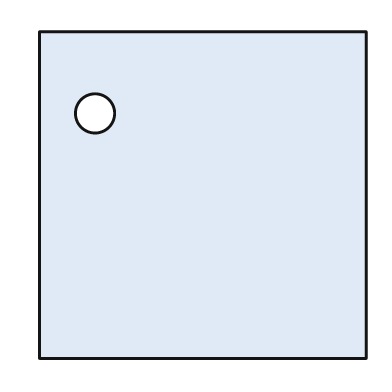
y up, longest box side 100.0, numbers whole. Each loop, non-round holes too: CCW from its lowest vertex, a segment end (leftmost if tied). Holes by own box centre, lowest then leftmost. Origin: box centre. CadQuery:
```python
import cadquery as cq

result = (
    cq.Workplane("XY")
    .moveTo(-50.0, -50.0)
    .lineTo(50.0, -50.0)
    .lineTo(50.0, 50.0)
    .lineTo(-50.0, 50.0)
    .close()
    .moveTo(-33.0, 25.0)
    .circle(6.0)
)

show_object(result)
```